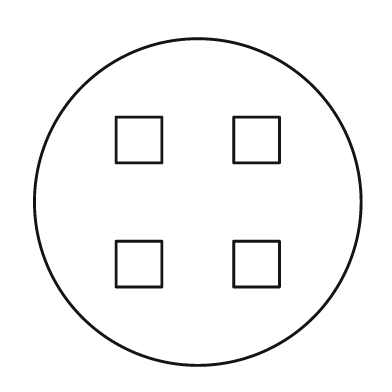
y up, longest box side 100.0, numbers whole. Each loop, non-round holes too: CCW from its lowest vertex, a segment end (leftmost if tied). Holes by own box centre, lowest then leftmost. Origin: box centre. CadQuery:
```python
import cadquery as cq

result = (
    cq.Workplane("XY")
    .moveTo(0.0, 0.0)
    .circle(50.0)
    .moveTo(-25.0, -26.0)
    .lineTo(-11.0, -26.0)
    .lineTo(-11.0, -12.0)
    .lineTo(-25.0, -12.0)
    .close()
    .moveTo(11.0, -26.0)
    .lineTo(25.0, -26.0)
    .lineTo(25.0, -12.0)
    .lineTo(11.0, -12.0)
    .close()
    .moveTo(-25.0, 12.0)
    .lineTo(-11.0, 12.0)
    .lineTo(-11.0, 26.0)
    .lineTo(-25.0, 26.0)
    .close()
    .moveTo(11.0, 12.0)
    .lineTo(25.0, 12.0)
    .lineTo(25.0, 26.0)
    .lineTo(11.0, 26.0)
    .close()
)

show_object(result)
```